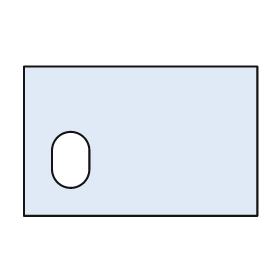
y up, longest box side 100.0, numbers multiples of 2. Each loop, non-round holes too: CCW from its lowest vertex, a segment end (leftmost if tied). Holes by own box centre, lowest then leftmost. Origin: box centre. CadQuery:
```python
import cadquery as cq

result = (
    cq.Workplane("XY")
    .moveTo(-50.0, -32.0)
    .lineTo(50.0, -32.0)
    .lineTo(50.0, 32.0)
    .lineTo(-50.0, 32.0)
    .close()
    .moveTo(-38.0, -12.0)
    .threePointArc((-30.0, -20.0), (-22.0, -12.0))
    .lineTo(-22.0, -4.0)
    .threePointArc((-30.0, 4.0), (-38.0, -4.0))
    .close()
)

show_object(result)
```